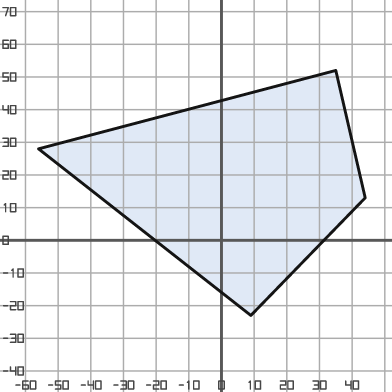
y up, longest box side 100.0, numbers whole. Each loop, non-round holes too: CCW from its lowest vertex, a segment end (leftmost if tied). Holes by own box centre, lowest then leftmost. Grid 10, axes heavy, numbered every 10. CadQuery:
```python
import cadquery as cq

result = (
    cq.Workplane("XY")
    .moveTo(9.0, -23.0)
    .lineTo(44.0, 13.0)
    .lineTo(35.0, 52.0)
    .lineTo(-56.0, 28.0)
    .close()
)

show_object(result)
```